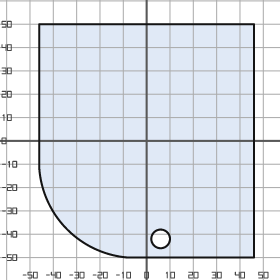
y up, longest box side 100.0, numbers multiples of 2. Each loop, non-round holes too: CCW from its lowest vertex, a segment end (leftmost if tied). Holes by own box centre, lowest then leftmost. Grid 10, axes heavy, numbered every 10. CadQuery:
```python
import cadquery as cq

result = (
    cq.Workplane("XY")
    .moveTo(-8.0, -50.0)
    .lineTo(46.0, -50.0)
    .lineTo(46.0, 50.0)
    .lineTo(-46.0, 50.0)
    .lineTo(-46.0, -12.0)
    .threePointArc((-34.0, -38.0), (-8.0, -50.0))
    .close()
    .moveTo(6.0, -42.0)
    .circle(4.0)
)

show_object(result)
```